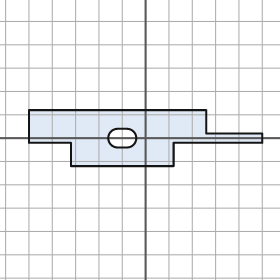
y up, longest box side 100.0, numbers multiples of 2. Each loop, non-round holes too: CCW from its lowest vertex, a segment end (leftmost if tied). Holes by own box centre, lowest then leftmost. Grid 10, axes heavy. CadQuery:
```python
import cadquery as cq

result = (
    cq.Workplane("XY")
    .moveTo(-32.0, -12.0)
    .lineTo(12.0, -12.0)
    .lineTo(12.0, -2.0)
    .lineTo(50.0, -2.0)
    .lineTo(50.0, 2.0)
    .lineTo(26.0, 2.0)
    .lineTo(26.0, 12.0)
    .lineTo(-50.0, 12.0)
    .lineTo(-50.0, -2.0)
    .lineTo(-32.0, -2.0)
    .close()
    .moveTo(-12.0, -4.0)
    .lineTo(-8.0, -4.0)
    .threePointArc((-4.0, 0.0), (-8.0, 4.0))
    .lineTo(-12.0, 4.0)
    .threePointArc((-16.0, 0.0), (-12.0, -4.0))
    .close()
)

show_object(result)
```